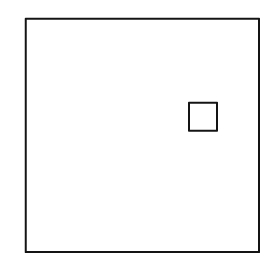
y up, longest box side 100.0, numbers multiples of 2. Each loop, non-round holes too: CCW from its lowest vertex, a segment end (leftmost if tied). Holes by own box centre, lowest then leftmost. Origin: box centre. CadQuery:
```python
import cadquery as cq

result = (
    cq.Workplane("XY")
    .moveTo(-50.0, -50.0)
    .lineTo(50.0, -50.0)
    .lineTo(50.0, 50.0)
    .lineTo(-50.0, 50.0)
    .close()
    .moveTo(20.0, 2.0)
    .lineTo(32.0, 2.0)
    .lineTo(32.0, 14.0)
    .lineTo(20.0, 14.0)
    .close()
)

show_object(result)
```